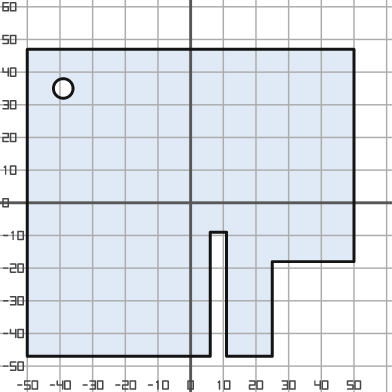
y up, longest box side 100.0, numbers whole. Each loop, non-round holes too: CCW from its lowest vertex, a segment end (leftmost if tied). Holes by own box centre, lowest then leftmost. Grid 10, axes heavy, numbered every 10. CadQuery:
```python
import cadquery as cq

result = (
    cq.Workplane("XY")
    .moveTo(-50.0, -47.0)
    .lineTo(6.0, -47.0)
    .lineTo(6.0, -9.0)
    .lineTo(11.0, -9.0)
    .lineTo(11.0, -47.0)
    .lineTo(25.0, -47.0)
    .lineTo(25.0, -18.0)
    .lineTo(50.0, -18.0)
    .lineTo(50.0, 47.0)
    .lineTo(-50.0, 47.0)
    .close()
    .moveTo(-39.0, 35.0)
    .circle(3.0)
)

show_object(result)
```